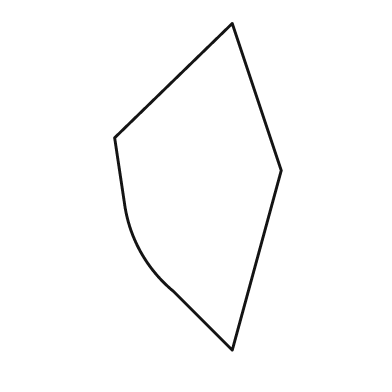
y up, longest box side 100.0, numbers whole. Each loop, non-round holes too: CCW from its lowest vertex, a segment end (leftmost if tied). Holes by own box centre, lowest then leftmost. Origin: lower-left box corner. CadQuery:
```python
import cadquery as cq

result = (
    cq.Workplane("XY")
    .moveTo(36.0, 0.0)
    .lineTo(51.0, 55.0)
    .lineTo(36.0, 100.0)
    .lineTo(0.0, 65.0)
    .lineTo(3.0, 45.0)
    .threePointArc((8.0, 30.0), (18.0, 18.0))
    .close()
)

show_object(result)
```